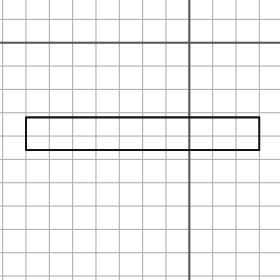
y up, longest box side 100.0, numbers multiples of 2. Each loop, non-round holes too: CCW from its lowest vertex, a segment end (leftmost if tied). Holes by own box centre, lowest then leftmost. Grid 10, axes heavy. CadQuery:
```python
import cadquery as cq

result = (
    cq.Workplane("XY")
    .moveTo(-70.0, -46.0)
    .lineTo(30.0, -46.0)
    .lineTo(30.0, -32.0)
    .lineTo(-70.0, -32.0)
    .close()
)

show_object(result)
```